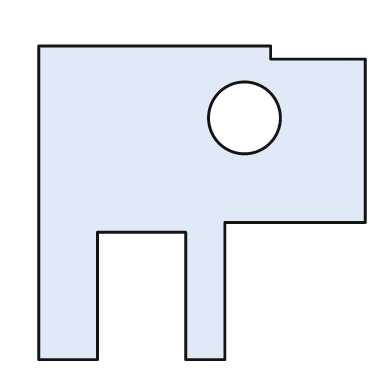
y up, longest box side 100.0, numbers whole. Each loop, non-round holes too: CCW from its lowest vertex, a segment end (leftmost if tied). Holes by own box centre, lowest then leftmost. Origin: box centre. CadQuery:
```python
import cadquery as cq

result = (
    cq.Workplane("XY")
    .moveTo(-50.0, -48.0)
    .lineTo(-32.0, -48.0)
    .lineTo(-32.0, -9.0)
    .lineTo(-5.0, -9.0)
    .lineTo(-5.0, -48.0)
    .lineTo(7.0, -48.0)
    .lineTo(7.0, -6.0)
    .lineTo(50.0, -6.0)
    .lineTo(50.0, 44.0)
    .lineTo(21.0, 44.0)
    .lineTo(21.0, 48.0)
    .lineTo(-50.0, 48.0)
    .close()
    .moveTo(13.0, 26.0)
    .circle(11.0)
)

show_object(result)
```